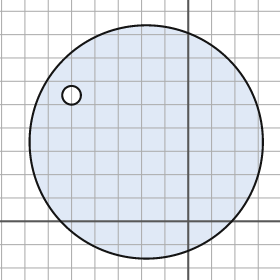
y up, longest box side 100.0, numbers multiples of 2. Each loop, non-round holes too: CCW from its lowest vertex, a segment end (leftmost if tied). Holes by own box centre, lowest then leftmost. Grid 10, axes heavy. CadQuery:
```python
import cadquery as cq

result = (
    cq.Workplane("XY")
    .moveTo(-18.0, 34.0)
    .circle(50.0)
    .moveTo(-50.0, 54.0)
    .circle(4.0)
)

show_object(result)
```